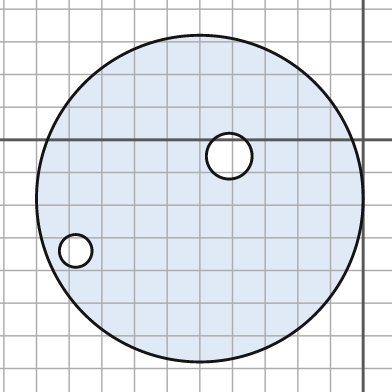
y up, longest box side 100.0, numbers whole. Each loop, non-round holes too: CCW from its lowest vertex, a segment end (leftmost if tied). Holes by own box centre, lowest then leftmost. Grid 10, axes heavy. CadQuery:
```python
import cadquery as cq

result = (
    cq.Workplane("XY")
    .moveTo(-50.0, -18.0)
    .circle(50.0)
    .moveTo(-88.0, -34.0)
    .circle(5.0)
    .moveTo(-41.0, -5.0)
    .circle(7.0)
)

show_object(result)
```